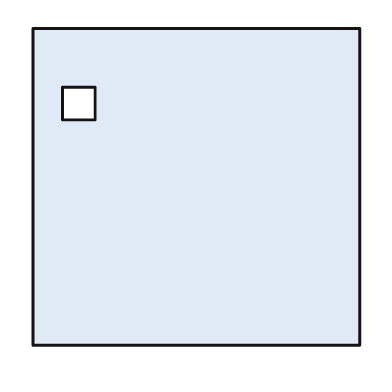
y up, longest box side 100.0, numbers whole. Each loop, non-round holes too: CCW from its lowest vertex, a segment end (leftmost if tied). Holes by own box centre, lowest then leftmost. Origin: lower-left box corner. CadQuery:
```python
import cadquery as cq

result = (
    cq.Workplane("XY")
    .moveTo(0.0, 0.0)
    .lineTo(100.0, 0.0)
    .lineTo(100.0, 97.0)
    .lineTo(0.0, 97.0)
    .close()
    .moveTo(9.0, 69.0)
    .lineTo(19.0, 69.0)
    .lineTo(19.0, 79.0)
    .lineTo(9.0, 79.0)
    .close()
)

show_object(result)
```